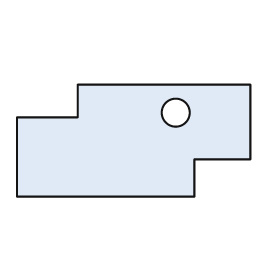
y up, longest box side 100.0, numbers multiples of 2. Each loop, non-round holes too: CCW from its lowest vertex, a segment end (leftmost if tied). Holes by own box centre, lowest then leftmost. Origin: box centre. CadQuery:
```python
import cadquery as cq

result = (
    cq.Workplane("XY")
    .moveTo(-50.0, -24.0)
    .lineTo(26.0, -24.0)
    .lineTo(26.0, -8.0)
    .lineTo(50.0, -8.0)
    .lineTo(50.0, 24.0)
    .lineTo(-24.0, 24.0)
    .lineTo(-24.0, 10.0)
    .lineTo(-50.0, 10.0)
    .close()
    .moveTo(18.0, 12.0)
    .circle(6.0)
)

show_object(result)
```